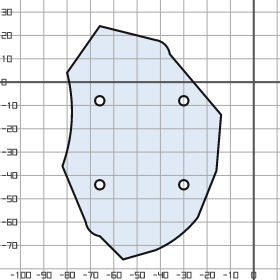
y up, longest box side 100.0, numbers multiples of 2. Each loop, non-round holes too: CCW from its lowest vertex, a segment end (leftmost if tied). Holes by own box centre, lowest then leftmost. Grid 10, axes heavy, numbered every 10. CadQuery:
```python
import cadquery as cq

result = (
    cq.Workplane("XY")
    .moveTo(-56.0, -76.0)
    .lineTo(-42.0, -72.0)
    .threePointArc((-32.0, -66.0), (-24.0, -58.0))
    .lineTo(-16.0, -38.0)
    .lineTo(-14.0, -14.0)
    .lineTo(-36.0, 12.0)
    .threePointArc((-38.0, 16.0), (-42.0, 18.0))
    .lineTo(-66.0, 24.0)
    .lineTo(-80.0, 4.0)
    .threePointArc((-78.0, -16.0), (-82.0, -36.0))
    .lineTo(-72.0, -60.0)
    .threePointArc((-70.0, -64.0), (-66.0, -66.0))
    .close()
    .moveTo(-66.0, -44.0)
    .circle(2.0)
    .moveTo(-30.0, -44.0)
    .circle(2.0)
    .moveTo(-66.0, -8.0)
    .circle(2.0)
    .moveTo(-30.0, -8.0)
    .circle(2.0)
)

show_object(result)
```